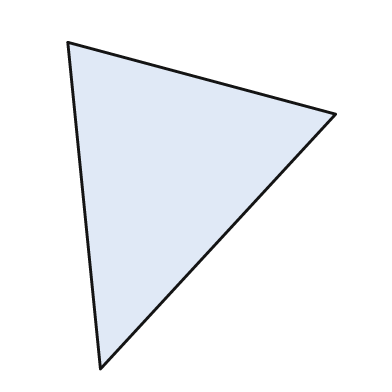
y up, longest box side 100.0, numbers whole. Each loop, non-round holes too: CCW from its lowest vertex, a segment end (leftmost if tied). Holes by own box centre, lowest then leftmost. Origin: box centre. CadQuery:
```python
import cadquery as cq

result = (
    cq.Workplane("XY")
    .moveTo(-31.0, -50.0)
    .lineTo(41.0, 28.0)
    .lineTo(-41.0, 50.0)
    .close()
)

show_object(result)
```